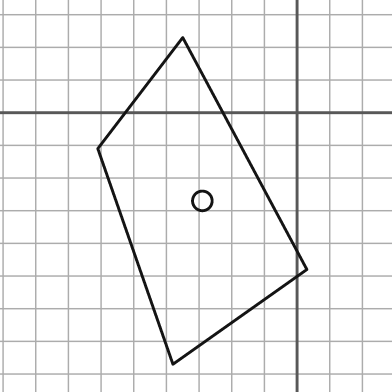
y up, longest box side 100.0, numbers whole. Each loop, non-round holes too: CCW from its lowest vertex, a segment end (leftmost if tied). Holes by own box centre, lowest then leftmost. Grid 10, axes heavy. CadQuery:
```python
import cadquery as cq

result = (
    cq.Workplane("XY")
    .moveTo(-38.0, -77.0)
    .lineTo(3.0, -48.0)
    .lineTo(-35.0, 23.0)
    .lineTo(-61.0, -11.0)
    .close()
    .moveTo(-29.0, -27.0)
    .circle(3.0)
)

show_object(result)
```